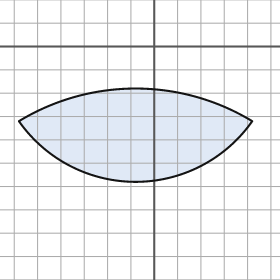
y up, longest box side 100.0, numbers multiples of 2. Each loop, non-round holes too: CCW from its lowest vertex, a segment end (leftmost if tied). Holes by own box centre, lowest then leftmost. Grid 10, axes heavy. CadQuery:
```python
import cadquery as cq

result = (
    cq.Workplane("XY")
    .moveTo(-58.0, -32.0)
    .threePointArc((-8.0, -58.0), (42.0, -32.0))
    .threePointArc((-8.0, -18.0), (-58.0, -32.0))
    .close()
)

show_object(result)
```